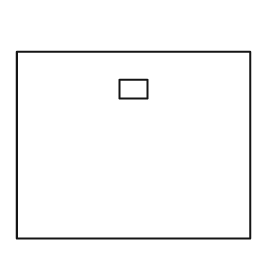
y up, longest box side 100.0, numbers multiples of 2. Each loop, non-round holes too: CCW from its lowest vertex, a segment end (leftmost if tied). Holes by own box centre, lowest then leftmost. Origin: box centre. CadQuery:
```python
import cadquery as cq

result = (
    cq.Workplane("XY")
    .moveTo(-50.0, -40.0)
    .lineTo(50.0, -40.0)
    .lineTo(50.0, 40.0)
    .lineTo(-50.0, 40.0)
    .close()
    .moveTo(-6.0, 20.0)
    .lineTo(6.0, 20.0)
    .lineTo(6.0, 28.0)
    .lineTo(-6.0, 28.0)
    .close()
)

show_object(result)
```